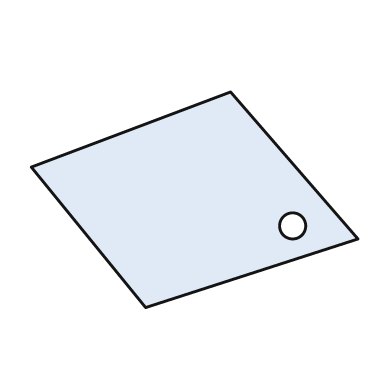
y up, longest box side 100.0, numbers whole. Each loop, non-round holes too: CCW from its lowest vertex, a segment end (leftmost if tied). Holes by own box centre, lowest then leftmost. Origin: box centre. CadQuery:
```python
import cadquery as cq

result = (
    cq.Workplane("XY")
    .moveTo(-15.0, -33.0)
    .lineTo(50.0, -12.0)
    .lineTo(11.0, 33.0)
    .lineTo(-50.0, 10.0)
    .close()
    .moveTo(30.0, -8.0)
    .circle(4.0)
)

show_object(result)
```